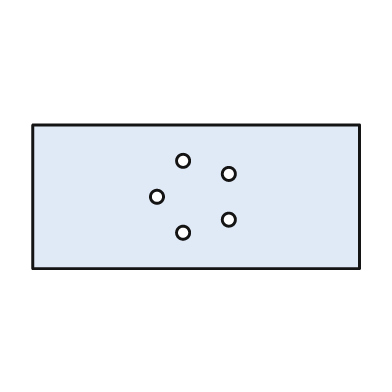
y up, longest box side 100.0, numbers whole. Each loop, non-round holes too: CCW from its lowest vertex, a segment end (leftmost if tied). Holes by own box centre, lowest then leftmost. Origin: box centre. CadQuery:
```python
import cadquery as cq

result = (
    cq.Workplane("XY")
    .moveTo(-50.0, -22.0)
    .lineTo(50.0, -22.0)
    .lineTo(50.0, 22.0)
    .lineTo(-50.0, 22.0)
    .close()
    .moveTo(-4.0, -11.0)
    .circle(2.0)
    .moveTo(10.0, -7.0)
    .circle(2.0)
    .moveTo(-12.0, 0.0)
    .circle(2.0)
    .moveTo(10.0, 7.0)
    .circle(2.0)
    .moveTo(-4.0, 11.0)
    .circle(2.0)
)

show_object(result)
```